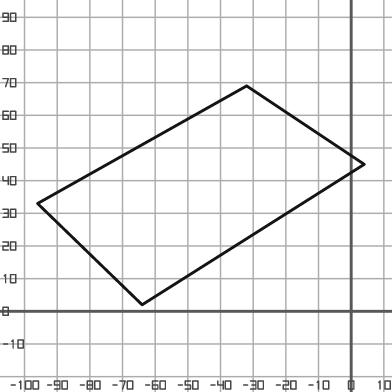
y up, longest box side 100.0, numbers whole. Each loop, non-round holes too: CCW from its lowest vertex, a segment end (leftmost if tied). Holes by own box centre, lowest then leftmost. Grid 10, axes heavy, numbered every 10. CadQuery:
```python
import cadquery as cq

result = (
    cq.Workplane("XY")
    .moveTo(-64.0, 2.0)
    .lineTo(4.0, 45.0)
    .lineTo(-32.0, 69.0)
    .lineTo(-96.0, 33.0)
    .close()
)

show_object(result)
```